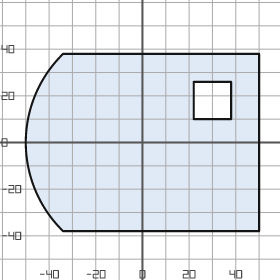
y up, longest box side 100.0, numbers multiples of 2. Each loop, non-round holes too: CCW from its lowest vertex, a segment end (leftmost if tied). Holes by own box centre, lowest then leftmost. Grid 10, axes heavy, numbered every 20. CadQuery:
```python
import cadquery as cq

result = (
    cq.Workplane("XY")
    .moveTo(-34.0, -38.0)
    .lineTo(50.0, -38.0)
    .lineTo(50.0, 38.0)
    .lineTo(-34.0, 38.0)
    .threePointArc((-50.0, 0.0), (-34.0, -38.0))
    .close()
    .moveTo(22.0, 10.0)
    .lineTo(38.0, 10.0)
    .lineTo(38.0, 26.0)
    .lineTo(22.0, 26.0)
    .close()
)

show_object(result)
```